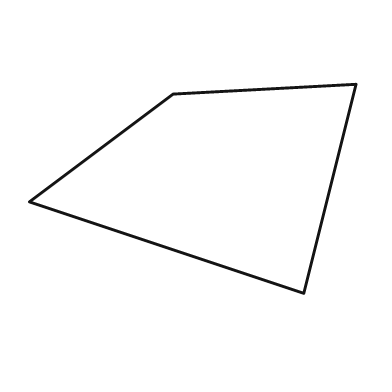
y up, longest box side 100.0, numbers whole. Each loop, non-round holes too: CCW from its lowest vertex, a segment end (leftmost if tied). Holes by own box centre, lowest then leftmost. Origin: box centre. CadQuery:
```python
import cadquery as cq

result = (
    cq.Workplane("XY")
    .moveTo(34.0, -32.0)
    .lineTo(50.0, 32.0)
    .lineTo(-6.0, 29.0)
    .lineTo(-50.0, -4.0)
    .close()
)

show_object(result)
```